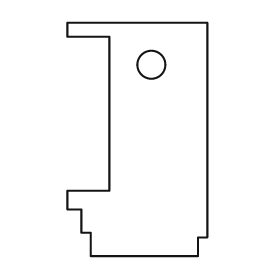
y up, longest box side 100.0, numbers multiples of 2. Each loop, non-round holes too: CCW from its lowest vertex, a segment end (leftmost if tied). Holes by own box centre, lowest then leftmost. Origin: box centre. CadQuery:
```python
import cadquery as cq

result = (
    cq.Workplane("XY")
    .moveTo(-20.0, -50.0)
    .lineTo(26.0, -50.0)
    .lineTo(26.0, -42.0)
    .lineTo(30.0, -42.0)
    .lineTo(30.0, 50.0)
    .lineTo(-30.0, 50.0)
    .lineTo(-30.0, 44.0)
    .lineTo(-12.0, 44.0)
    .lineTo(-12.0, -22.0)
    .lineTo(-30.0, -22.0)
    .lineTo(-30.0, -30.0)
    .lineTo(-24.0, -30.0)
    .lineTo(-24.0, -40.0)
    .lineTo(-20.0, -40.0)
    .close()
    .moveTo(6.0, 32.0)
    .circle(6.0)
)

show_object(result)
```